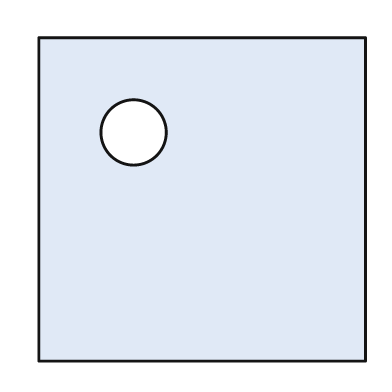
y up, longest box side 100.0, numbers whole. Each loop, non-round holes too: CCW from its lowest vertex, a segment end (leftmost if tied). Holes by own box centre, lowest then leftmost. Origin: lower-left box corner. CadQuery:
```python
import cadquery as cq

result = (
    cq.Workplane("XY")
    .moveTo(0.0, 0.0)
    .lineTo(100.0, 0.0)
    .lineTo(100.0, 99.0)
    .lineTo(0.0, 99.0)
    .close()
    .moveTo(29.0, 70.0)
    .circle(10.0)
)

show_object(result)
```